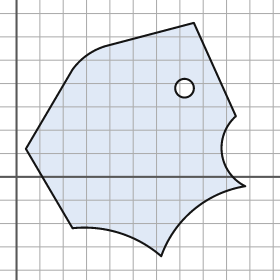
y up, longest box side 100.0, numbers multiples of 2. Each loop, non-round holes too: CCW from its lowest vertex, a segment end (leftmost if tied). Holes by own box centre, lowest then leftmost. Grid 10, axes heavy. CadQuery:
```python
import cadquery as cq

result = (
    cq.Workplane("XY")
    .moveTo(62.0, -34.0)
    .threePointArc((76.0, -14.0), (98.0, -4.0))
    .threePointArc((88.0, 10.0), (94.0, 26.0))
    .lineTo(76.0, 66.0)
    .lineTo(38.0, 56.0)
    .threePointArc((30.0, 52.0), (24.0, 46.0))
    .lineTo(4.0, 12.0)
    .lineTo(24.0, -22.0)
    .threePointArc((44.0, -24.0), (62.0, -34.0))
    .close()
    .moveTo(72.0, 38.0)
    .circle(4.0)
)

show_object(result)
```